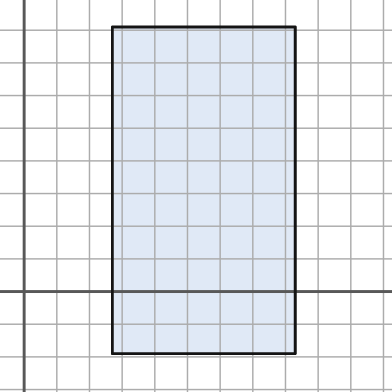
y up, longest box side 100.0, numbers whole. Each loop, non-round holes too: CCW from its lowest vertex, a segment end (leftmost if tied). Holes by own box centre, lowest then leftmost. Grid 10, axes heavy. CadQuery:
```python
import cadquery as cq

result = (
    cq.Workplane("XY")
    .moveTo(27.0, -19.0)
    .lineTo(83.0, -19.0)
    .lineTo(83.0, 81.0)
    .lineTo(27.0, 81.0)
    .close()
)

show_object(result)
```